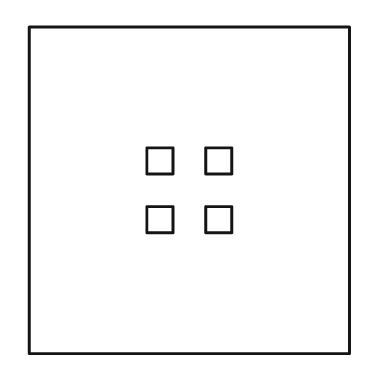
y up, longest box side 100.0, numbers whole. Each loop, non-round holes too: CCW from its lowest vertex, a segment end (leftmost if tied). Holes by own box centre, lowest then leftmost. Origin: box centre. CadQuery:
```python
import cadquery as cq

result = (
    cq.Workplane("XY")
    .moveTo(-49.0, -50.0)
    .lineTo(49.0, -50.0)
    .lineTo(49.0, 50.0)
    .lineTo(-49.0, 50.0)
    .close()
    .moveTo(-13.0, -13.0)
    .lineTo(-5.0, -13.0)
    .lineTo(-5.0, -5.0)
    .lineTo(-13.0, -5.0)
    .close()
    .moveTo(5.0, -13.0)
    .lineTo(13.0, -13.0)
    .lineTo(13.0, -5.0)
    .lineTo(5.0, -5.0)
    .close()
    .moveTo(-13.0, 5.0)
    .lineTo(-5.0, 5.0)
    .lineTo(-5.0, 13.0)
    .lineTo(-13.0, 13.0)
    .close()
    .moveTo(5.0, 5.0)
    .lineTo(13.0, 5.0)
    .lineTo(13.0, 13.0)
    .lineTo(5.0, 13.0)
    .close()
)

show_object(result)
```